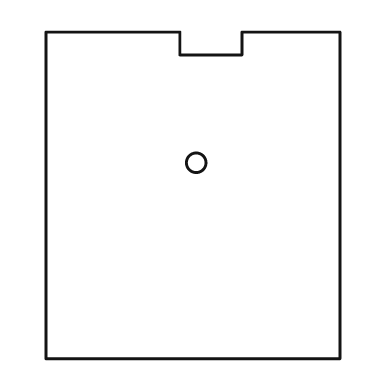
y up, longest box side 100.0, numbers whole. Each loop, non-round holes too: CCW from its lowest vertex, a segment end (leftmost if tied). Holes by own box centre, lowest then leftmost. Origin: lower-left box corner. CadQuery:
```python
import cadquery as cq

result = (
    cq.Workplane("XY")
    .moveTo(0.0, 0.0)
    .lineTo(90.0, 0.0)
    .lineTo(90.0, 100.0)
    .lineTo(60.0, 100.0)
    .lineTo(60.0, 93.0)
    .lineTo(41.0, 93.0)
    .lineTo(41.0, 100.0)
    .lineTo(0.0, 100.0)
    .close()
    .moveTo(46.0, 60.0)
    .circle(3.0)
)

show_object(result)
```